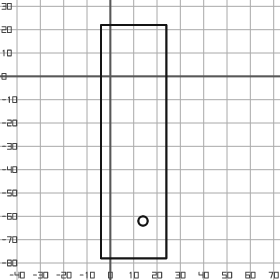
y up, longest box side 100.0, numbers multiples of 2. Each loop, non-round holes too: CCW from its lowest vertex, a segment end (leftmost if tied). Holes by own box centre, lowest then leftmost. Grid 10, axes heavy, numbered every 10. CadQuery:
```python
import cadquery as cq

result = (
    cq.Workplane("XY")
    .moveTo(-4.0, -78.0)
    .lineTo(24.0, -78.0)
    .lineTo(24.0, 22.0)
    .lineTo(-4.0, 22.0)
    .close()
    .moveTo(14.0, -62.0)
    .circle(2.0)
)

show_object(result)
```